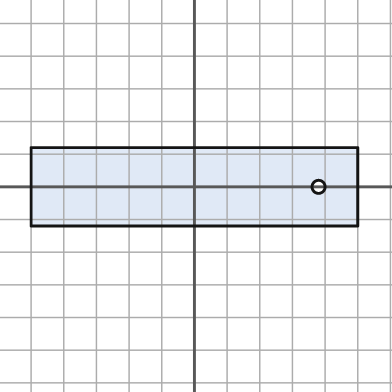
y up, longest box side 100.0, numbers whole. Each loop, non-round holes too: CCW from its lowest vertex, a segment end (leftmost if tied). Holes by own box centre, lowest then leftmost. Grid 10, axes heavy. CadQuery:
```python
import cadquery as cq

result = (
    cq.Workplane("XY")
    .moveTo(-50.0, -12.0)
    .lineTo(50.0, -12.0)
    .lineTo(50.0, 12.0)
    .lineTo(-50.0, 12.0)
    .close()
    .moveTo(38.0, 0.0)
    .circle(2.0)
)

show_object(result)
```